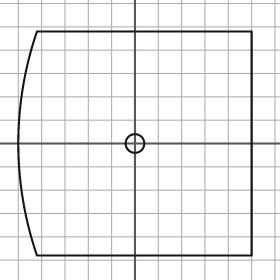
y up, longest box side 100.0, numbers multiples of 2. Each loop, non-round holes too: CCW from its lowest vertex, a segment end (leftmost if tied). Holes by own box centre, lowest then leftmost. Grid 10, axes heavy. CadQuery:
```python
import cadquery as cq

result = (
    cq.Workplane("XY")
    .moveTo(-42.0, -48.0)
    .lineTo(50.0, -48.0)
    .lineTo(50.0, 48.0)
    .lineTo(-42.0, 48.0)
    .threePointArc((-50.0, 0.0), (-42.0, -48.0))
    .close()
    .moveTo(0.0, 0.0)
    .circle(4.0)
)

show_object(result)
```